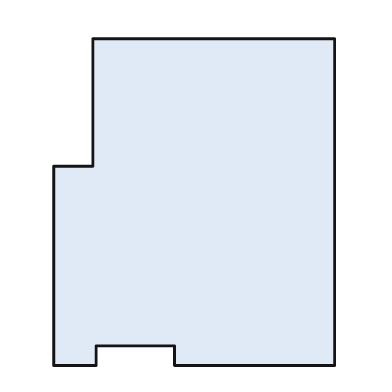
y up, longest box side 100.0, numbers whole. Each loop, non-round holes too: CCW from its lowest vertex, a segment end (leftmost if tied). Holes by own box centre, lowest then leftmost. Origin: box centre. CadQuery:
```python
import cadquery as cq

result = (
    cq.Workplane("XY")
    .moveTo(-43.0, -50.0)
    .lineTo(-30.0, -50.0)
    .lineTo(-30.0, -44.0)
    .lineTo(-6.0, -44.0)
    .lineTo(-6.0, -50.0)
    .lineTo(43.0, -50.0)
    .lineTo(43.0, 50.0)
    .lineTo(-31.0, 50.0)
    .lineTo(-31.0, 11.0)
    .lineTo(-43.0, 11.0)
    .close()
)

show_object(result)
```